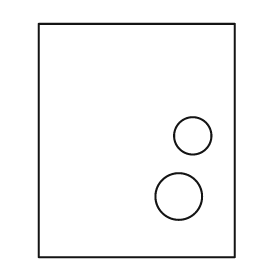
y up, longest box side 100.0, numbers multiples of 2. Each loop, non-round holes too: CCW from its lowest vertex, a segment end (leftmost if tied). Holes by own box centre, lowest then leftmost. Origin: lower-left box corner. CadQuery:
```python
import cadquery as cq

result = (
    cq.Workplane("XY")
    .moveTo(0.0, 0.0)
    .lineTo(84.0, 0.0)
    .lineTo(84.0, 100.0)
    .lineTo(0.0, 100.0)
    .close()
    .moveTo(60.0, 26.0)
    .circle(10.0)
    .moveTo(66.0, 52.0)
    .circle(8.0)
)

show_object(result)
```